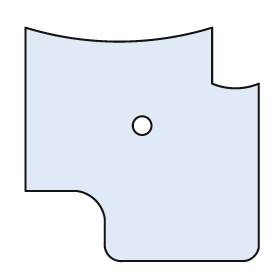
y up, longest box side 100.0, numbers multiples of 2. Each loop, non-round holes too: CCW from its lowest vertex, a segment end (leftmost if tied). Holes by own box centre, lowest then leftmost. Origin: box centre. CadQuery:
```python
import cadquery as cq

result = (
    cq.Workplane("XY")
    .moveTo(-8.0, -50.0)
    .lineTo(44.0, -50.0)
    .threePointArc((48.0, -48.0), (50.0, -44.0))
    .lineTo(50.0, 26.0)
    .threePointArc((40.0, 24.0), (30.0, 26.0))
    .lineTo(30.0, 50.0)
    .threePointArc((-10.0, 44.0), (-50.0, 50.0))
    .lineTo(-50.0, -20.0)
    .lineTo(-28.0, -20.0)
    .threePointArc((-20.0, -24.0), (-16.0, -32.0))
    .lineTo(-16.0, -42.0)
    .threePointArc((-14.0, -48.0), (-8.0, -50.0))
    .close()
    .moveTo(0.0, 8.0)
    .circle(4.0)
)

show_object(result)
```